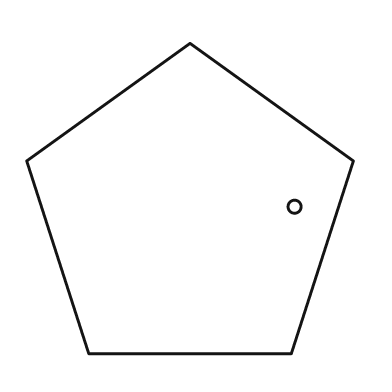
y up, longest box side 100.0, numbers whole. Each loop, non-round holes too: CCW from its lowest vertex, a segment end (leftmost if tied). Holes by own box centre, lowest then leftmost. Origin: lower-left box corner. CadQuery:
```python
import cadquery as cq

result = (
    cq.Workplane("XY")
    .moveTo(19.0, 0.0)
    .lineTo(81.0, 0.0)
    .lineTo(100.0, 59.0)
    .lineTo(50.0, 95.0)
    .lineTo(0.0, 59.0)
    .close()
    .moveTo(82.0, 45.0)
    .circle(2.0)
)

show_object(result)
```